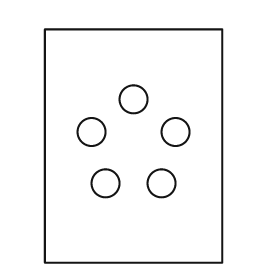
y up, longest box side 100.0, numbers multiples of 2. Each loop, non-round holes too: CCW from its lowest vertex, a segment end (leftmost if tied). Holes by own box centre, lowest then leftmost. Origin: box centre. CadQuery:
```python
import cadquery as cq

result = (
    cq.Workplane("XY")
    .moveTo(-38.0, -50.0)
    .lineTo(38.0, -50.0)
    .lineTo(38.0, 50.0)
    .lineTo(-38.0, 50.0)
    .close()
    .moveTo(-12.0, -16.0)
    .circle(6.0)
    .moveTo(12.0, -16.0)
    .circle(6.0)
    .moveTo(-18.0, 6.0)
    .circle(6.0)
    .moveTo(18.0, 6.0)
    .circle(6.0)
    .moveTo(0.0, 20.0)
    .circle(6.0)
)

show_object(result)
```